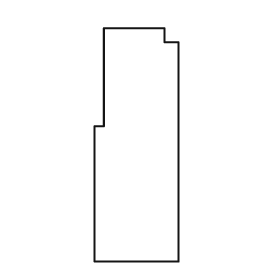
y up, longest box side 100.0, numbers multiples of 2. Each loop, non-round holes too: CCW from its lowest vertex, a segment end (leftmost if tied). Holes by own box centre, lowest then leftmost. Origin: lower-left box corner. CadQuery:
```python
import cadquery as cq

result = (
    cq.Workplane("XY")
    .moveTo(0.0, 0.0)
    .lineTo(36.0, 0.0)
    .lineTo(36.0, 94.0)
    .lineTo(30.0, 94.0)
    .lineTo(30.0, 100.0)
    .lineTo(4.0, 100.0)
    .lineTo(4.0, 58.0)
    .lineTo(0.0, 58.0)
    .close()
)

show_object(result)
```